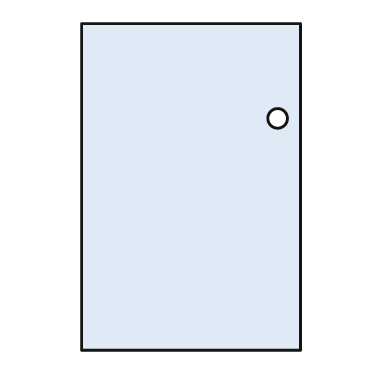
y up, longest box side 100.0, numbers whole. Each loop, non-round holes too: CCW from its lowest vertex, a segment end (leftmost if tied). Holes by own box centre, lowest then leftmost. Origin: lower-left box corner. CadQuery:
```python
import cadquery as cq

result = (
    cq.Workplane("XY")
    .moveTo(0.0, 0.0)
    .lineTo(67.0, 0.0)
    .lineTo(67.0, 100.0)
    .lineTo(0.0, 100.0)
    .close()
    .moveTo(60.0, 71.0)
    .circle(3.0)
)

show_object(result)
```